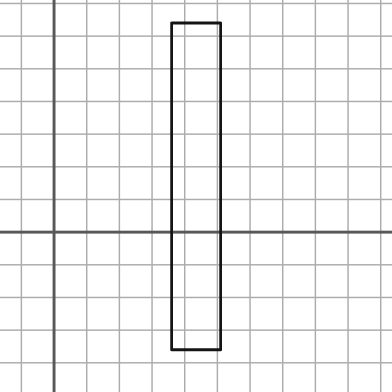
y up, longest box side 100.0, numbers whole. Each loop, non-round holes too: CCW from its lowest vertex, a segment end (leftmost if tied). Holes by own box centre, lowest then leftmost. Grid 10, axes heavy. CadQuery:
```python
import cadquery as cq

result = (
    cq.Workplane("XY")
    .moveTo(36.0, -36.0)
    .lineTo(51.0, -36.0)
    .lineTo(51.0, 64.0)
    .lineTo(36.0, 64.0)
    .close()
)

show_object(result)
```